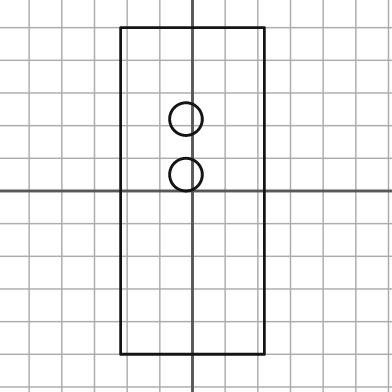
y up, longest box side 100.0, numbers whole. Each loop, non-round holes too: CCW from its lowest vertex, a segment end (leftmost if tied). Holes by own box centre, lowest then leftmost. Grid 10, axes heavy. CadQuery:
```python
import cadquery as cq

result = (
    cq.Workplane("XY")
    .moveTo(-22.0, -50.0)
    .lineTo(22.0, -50.0)
    .lineTo(22.0, 50.0)
    .lineTo(-22.0, 50.0)
    .close()
    .moveTo(-2.0, 5.0)
    .circle(5.0)
    .moveTo(-2.0, 22.0)
    .circle(5.0)
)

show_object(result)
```